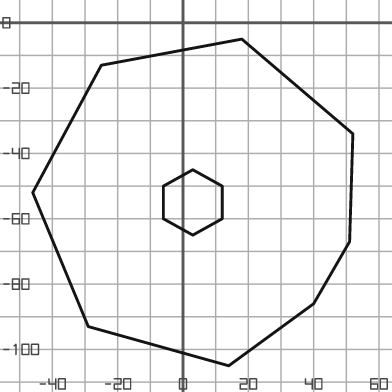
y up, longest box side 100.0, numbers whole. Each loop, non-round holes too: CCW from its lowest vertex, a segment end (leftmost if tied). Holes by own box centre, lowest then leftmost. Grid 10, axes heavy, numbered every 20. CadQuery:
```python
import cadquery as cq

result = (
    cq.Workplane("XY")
    .moveTo(14.0, -105.0)
    .lineTo(40.0, -86.0)
    .lineTo(51.0, -67.0)
    .lineTo(52.0, -34.0)
    .lineTo(18.0, -5.0)
    .lineTo(-25.0, -13.0)
    .lineTo(-46.0, -52.0)
    .lineTo(-29.0, -93.0)
    .close()
    .moveTo(3.0, -65.0)
    .lineTo(12.0, -60.0)
    .lineTo(12.0, -50.0)
    .lineTo(3.0, -45.0)
    .lineTo(-6.0, -50.0)
    .lineTo(-6.0, -60.0)
    .close()
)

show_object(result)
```